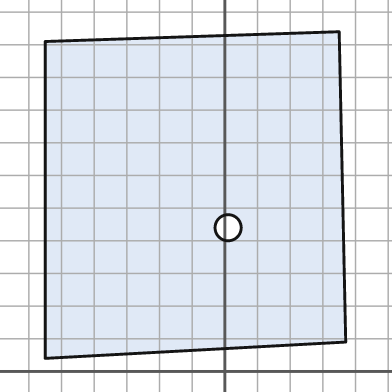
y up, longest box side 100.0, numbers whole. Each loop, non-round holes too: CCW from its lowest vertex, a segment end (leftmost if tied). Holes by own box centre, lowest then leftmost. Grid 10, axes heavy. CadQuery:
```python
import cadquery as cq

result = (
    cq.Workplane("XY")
    .moveTo(-55.0, 4.0)
    .lineTo(37.0, 9.0)
    .lineTo(35.0, 104.0)
    .lineTo(-55.0, 101.0)
    .close()
    .moveTo(1.0, 44.0)
    .circle(4.0)
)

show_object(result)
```